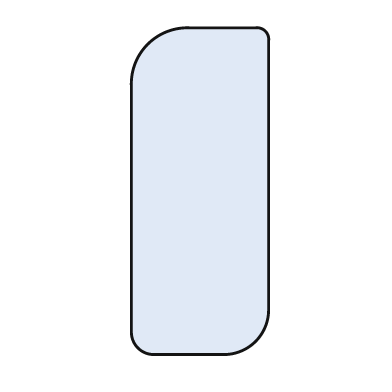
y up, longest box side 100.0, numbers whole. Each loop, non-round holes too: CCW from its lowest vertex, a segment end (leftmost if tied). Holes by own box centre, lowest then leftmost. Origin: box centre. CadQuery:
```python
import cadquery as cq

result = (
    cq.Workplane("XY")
    .moveTo(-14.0, -50.0)
    .lineTo(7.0, -50.0)
    .threePointArc((17.0, -46.0), (21.0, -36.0))
    .lineTo(21.0, 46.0)
    .threePointArc((20.0, 49.0), (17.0, 50.0))
    .lineTo(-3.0, 50.0)
    .threePointArc((-16.0, 45.0), (-21.0, 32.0))
    .lineTo(-21.0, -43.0)
    .threePointArc((-19.0, -48.0), (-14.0, -50.0))
    .close()
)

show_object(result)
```